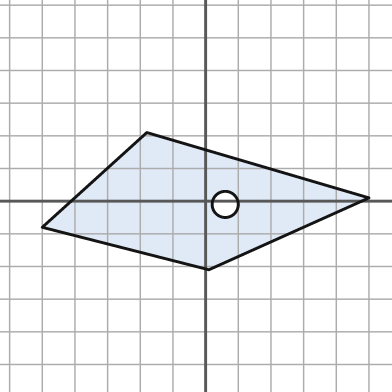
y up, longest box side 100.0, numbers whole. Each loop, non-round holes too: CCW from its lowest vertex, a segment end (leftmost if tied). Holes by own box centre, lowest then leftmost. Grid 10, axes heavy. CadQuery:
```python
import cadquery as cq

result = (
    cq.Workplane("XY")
    .moveTo(1.0, -21.0)
    .lineTo(50.0, 1.0)
    .lineTo(-18.0, 21.0)
    .lineTo(-50.0, -8.0)
    .close()
    .moveTo(6.0, -1.0)
    .circle(4.0)
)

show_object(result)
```